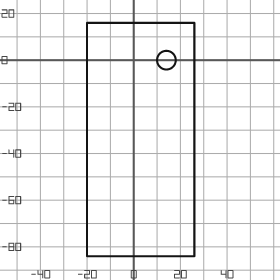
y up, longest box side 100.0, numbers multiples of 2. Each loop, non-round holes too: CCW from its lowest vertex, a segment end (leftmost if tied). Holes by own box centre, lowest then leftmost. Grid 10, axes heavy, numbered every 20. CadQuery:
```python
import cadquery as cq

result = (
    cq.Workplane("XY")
    .moveTo(-20.0, -84.0)
    .lineTo(26.0, -84.0)
    .lineTo(26.0, 16.0)
    .lineTo(-20.0, 16.0)
    .close()
    .moveTo(14.0, 0.0)
    .circle(4.0)
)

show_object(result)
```